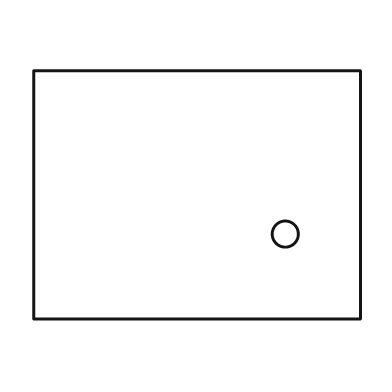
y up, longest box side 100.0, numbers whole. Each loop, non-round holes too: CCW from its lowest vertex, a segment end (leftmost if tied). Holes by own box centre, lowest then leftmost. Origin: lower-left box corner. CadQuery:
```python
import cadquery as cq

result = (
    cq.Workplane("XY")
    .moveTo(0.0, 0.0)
    .lineTo(100.0, 0.0)
    .lineTo(100.0, 76.0)
    .lineTo(0.0, 76.0)
    .close()
    .moveTo(77.0, 26.0)
    .circle(4.0)
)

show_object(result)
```